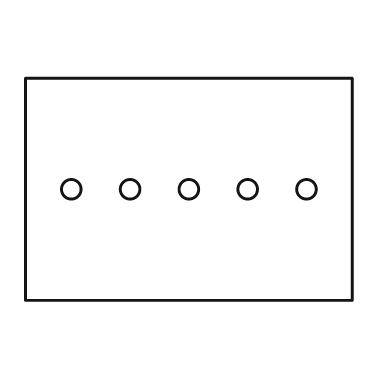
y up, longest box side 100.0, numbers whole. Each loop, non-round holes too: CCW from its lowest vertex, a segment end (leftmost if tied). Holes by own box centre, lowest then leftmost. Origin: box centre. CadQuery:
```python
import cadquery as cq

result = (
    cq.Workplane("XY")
    .moveTo(-50.0, -34.0)
    .lineTo(50.0, -34.0)
    .lineTo(50.0, 34.0)
    .lineTo(-50.0, 34.0)
    .close()
    .moveTo(-36.0, 0.0)
    .circle(3.0)
    .moveTo(-18.0, 0.0)
    .circle(3.0)
    .moveTo(0.0, 0.0)
    .circle(3.0)
    .moveTo(18.0, 0.0)
    .circle(3.0)
    .moveTo(36.0, 0.0)
    .circle(3.0)
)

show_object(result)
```